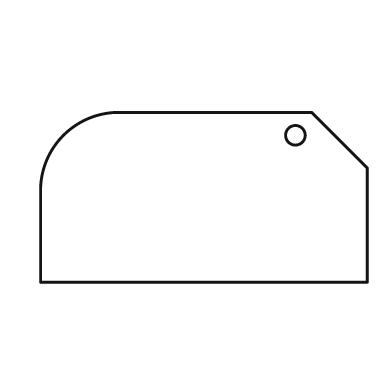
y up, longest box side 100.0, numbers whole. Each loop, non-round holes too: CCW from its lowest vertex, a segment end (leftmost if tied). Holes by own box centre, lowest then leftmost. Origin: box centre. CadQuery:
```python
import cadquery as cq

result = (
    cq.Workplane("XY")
    .moveTo(-50.0, -26.0)
    .lineTo(50.0, -26.0)
    .lineTo(50.0, 9.0)
    .lineTo(33.0, 26.0)
    .lineTo(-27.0, 26.0)
    .threePointArc((-43.0, 19.0), (-50.0, 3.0))
    .close()
    .moveTo(28.0, 19.0)
    .circle(3.0)
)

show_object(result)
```